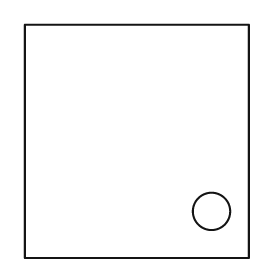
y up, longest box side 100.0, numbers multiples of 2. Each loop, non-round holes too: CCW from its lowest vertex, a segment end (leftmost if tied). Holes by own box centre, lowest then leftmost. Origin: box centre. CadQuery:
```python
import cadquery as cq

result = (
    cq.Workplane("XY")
    .moveTo(-48.0, -50.0)
    .lineTo(48.0, -50.0)
    .lineTo(48.0, 50.0)
    .lineTo(-48.0, 50.0)
    .close()
    .moveTo(32.0, -30.0)
    .circle(8.0)
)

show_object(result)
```